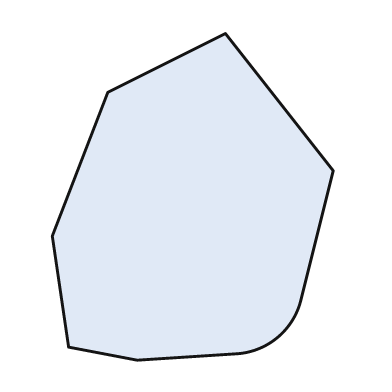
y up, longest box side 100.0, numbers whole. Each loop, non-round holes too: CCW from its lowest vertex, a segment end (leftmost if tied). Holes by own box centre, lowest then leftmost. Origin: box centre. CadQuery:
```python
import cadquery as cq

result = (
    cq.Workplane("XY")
    .moveTo(-17.0, -50.0)
    .lineTo(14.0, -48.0)
    .threePointArc((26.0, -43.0), (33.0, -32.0))
    .lineTo(43.0, 8.0)
    .lineTo(10.0, 50.0)
    .lineTo(-26.0, 32.0)
    .lineTo(-43.0, -12.0)
    .lineTo(-38.0, -46.0)
    .close()
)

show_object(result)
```